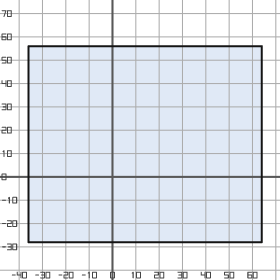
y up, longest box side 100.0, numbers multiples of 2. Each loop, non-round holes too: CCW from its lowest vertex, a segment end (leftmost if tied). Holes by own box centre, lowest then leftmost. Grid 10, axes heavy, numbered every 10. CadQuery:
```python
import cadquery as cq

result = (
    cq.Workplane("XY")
    .moveTo(-36.0, -28.0)
    .lineTo(64.0, -28.0)
    .lineTo(64.0, 56.0)
    .lineTo(-36.0, 56.0)
    .close()
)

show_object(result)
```